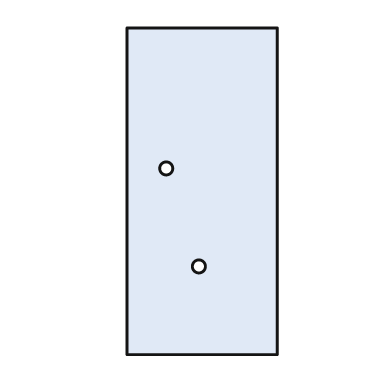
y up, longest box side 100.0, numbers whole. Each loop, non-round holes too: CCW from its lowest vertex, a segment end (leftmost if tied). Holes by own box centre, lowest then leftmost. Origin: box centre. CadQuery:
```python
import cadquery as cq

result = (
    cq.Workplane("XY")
    .moveTo(-23.0, -50.0)
    .lineTo(23.0, -50.0)
    .lineTo(23.0, 50.0)
    .lineTo(-23.0, 50.0)
    .close()
    .moveTo(-1.0, -23.0)
    .circle(2.0)
    .moveTo(-11.0, 7.0)
    .circle(2.0)
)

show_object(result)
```